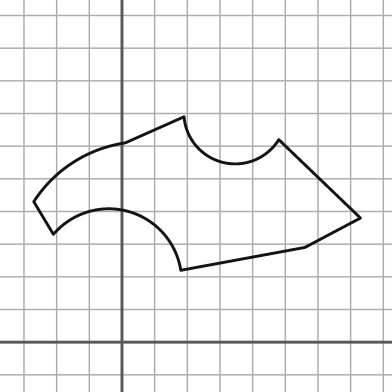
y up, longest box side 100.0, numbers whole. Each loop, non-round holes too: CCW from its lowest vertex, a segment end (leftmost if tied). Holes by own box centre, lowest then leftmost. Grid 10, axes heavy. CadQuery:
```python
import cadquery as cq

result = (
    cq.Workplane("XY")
    .moveTo(18.0, 22.0)
    .lineTo(56.0, 29.0)
    .lineTo(73.0, 38.0)
    .lineTo(48.0, 62.0)
    .threePointArc((31.0, 55.0), (19.0, 69.0))
    .lineTo(1.0, 61.0)
    .threePointArc((-15.0, 55.0), (-27.0, 43.0))
    .lineTo(-21.0, 33.0)
    .threePointArc((2.0, 40.0), (18.0, 22.0))
    .close()
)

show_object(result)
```